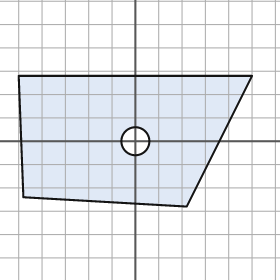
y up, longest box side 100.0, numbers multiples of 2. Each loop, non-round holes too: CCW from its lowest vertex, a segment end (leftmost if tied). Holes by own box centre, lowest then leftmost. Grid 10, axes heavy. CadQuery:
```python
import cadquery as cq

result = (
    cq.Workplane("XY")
    .moveTo(22.0, -28.0)
    .lineTo(50.0, 28.0)
    .lineTo(-50.0, 28.0)
    .lineTo(-48.0, -24.0)
    .close()
    .moveTo(0.0, 0.0)
    .circle(6.0)
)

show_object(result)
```